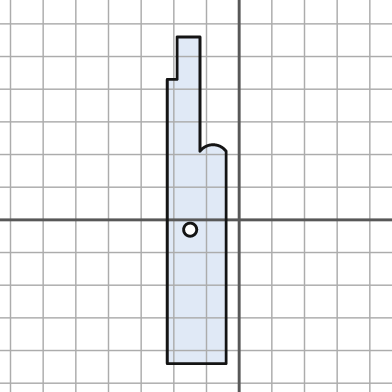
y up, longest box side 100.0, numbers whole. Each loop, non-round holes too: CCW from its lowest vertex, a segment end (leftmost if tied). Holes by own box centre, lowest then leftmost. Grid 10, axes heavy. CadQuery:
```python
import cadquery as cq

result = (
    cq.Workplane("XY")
    .moveTo(-22.0, -44.0)
    .lineTo(-4.0, -44.0)
    .lineTo(-4.0, 21.0)
    .threePointArc((-8.0, 23.0), (-12.0, 21.0))
    .lineTo(-12.0, 56.0)
    .lineTo(-19.0, 56.0)
    .lineTo(-19.0, 43.0)
    .lineTo(-22.0, 43.0)
    .close()
    .moveTo(-15.0, -3.0)
    .circle(2.0)
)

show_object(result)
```